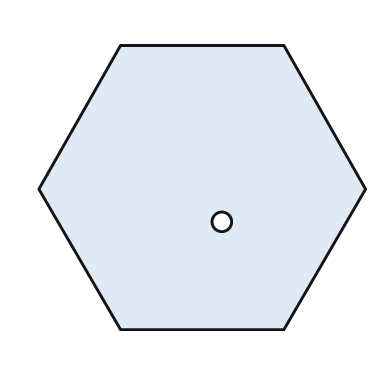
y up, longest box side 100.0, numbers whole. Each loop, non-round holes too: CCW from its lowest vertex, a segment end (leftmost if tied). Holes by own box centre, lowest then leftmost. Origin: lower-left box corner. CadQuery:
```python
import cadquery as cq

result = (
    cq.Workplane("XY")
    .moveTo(25.0, 0.0)
    .lineTo(75.0, 0.0)
    .lineTo(100.0, 43.0)
    .lineTo(75.0, 87.0)
    .lineTo(25.0, 87.0)
    .lineTo(0.0, 43.0)
    .close()
    .moveTo(56.0, 33.0)
    .circle(3.0)
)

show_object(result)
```